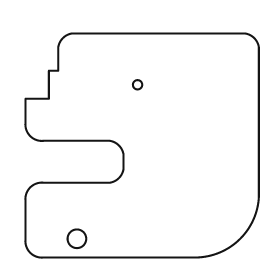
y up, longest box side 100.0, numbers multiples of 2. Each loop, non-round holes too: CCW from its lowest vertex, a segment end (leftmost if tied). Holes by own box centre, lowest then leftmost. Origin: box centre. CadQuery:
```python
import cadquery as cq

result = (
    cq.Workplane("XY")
    .moveTo(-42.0, -48.0)
    .lineTo(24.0, -48.0)
    .threePointArc((42.0, -40.0), (50.0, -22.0))
    .lineTo(50.0, 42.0)
    .threePointArc((48.0, 46.0), (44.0, 48.0))
    .lineTo(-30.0, 48.0)
    .threePointArc((-34.0, 46.0), (-36.0, 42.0))
    .lineTo(-36.0, 32.0)
    .lineTo(-40.0, 32.0)
    .lineTo(-40.0, 20.0)
    .lineTo(-50.0, 20.0)
    .lineTo(-50.0, 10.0)
    .threePointArc((-48.0, 4.0), (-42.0, 2.0))
    .lineTo(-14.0, 2.0)
    .threePointArc((-10.0, 0.0), (-8.0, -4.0))
    .lineTo(-8.0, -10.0)
    .threePointArc((-10.0, -14.0), (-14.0, -16.0))
    .lineTo(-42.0, -16.0)
    .threePointArc((-48.0, -18.0), (-50.0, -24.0))
    .lineTo(-50.0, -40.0)
    .threePointArc((-48.0, -46.0), (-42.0, -48.0))
    .close()
    .moveTo(-28.0, -40.0)
    .circle(4.0)
    .moveTo(-2.0, 26.0)
    .circle(2.0)
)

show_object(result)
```